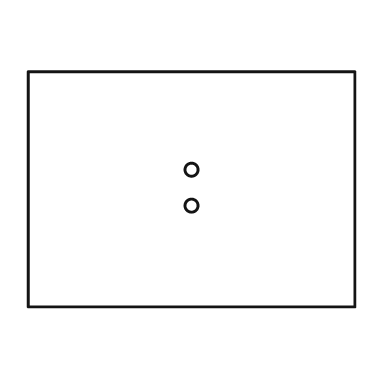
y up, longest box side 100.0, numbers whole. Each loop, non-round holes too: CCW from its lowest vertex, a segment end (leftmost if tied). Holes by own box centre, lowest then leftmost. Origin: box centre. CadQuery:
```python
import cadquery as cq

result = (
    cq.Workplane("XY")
    .moveTo(-50.0, -36.0)
    .lineTo(50.0, -36.0)
    .lineTo(50.0, 36.0)
    .lineTo(-50.0, 36.0)
    .close()
    .moveTo(0.0, -5.0)
    .circle(2.0)
    .moveTo(0.0, 6.0)
    .circle(2.0)
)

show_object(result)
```